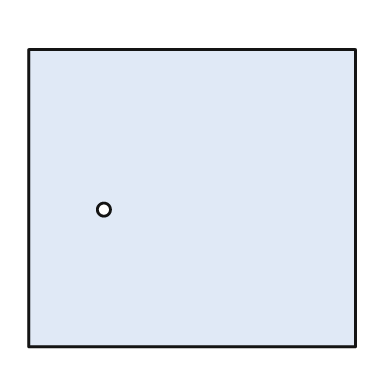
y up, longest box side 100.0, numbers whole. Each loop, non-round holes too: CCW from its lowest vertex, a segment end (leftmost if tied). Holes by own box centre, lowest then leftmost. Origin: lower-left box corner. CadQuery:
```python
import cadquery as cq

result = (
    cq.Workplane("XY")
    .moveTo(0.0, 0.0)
    .lineTo(100.0, 0.0)
    .lineTo(100.0, 91.0)
    .lineTo(0.0, 91.0)
    .close()
    .moveTo(23.0, 42.0)
    .circle(2.0)
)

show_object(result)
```